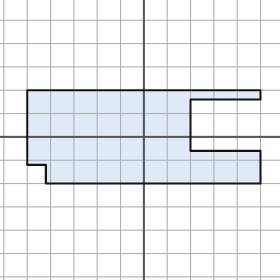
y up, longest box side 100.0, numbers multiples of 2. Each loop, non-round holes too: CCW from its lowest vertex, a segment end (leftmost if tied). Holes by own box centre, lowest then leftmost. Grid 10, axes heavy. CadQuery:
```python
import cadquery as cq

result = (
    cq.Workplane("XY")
    .moveTo(-42.0, -20.0)
    .lineTo(50.0, -20.0)
    .lineTo(50.0, -6.0)
    .lineTo(20.0, -6.0)
    .lineTo(20.0, 16.0)
    .lineTo(50.0, 16.0)
    .lineTo(50.0, 20.0)
    .lineTo(-50.0, 20.0)
    .lineTo(-50.0, -12.0)
    .lineTo(-42.0, -12.0)
    .close()
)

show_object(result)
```